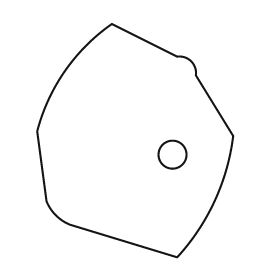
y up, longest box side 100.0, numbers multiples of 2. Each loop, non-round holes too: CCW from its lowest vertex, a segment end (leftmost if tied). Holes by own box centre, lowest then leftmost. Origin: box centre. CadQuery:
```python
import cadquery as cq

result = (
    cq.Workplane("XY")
    .moveTo(18.0, -50.0)
    .threePointArc((34.0, -26.0), (42.0, 2.0))
    .lineTo(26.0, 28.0)
    .threePointArc((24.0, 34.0), (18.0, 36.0))
    .lineTo(-10.0, 50.0)
    .threePointArc((-30.0, 30.0), (-42.0, 4.0))
    .lineTo(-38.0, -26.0)
    .threePointArc((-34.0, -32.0), (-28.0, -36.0))
    .close()
    .moveTo(16.0, -6.0)
    .circle(6.0)
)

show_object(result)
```